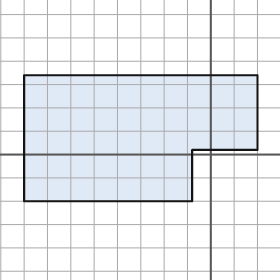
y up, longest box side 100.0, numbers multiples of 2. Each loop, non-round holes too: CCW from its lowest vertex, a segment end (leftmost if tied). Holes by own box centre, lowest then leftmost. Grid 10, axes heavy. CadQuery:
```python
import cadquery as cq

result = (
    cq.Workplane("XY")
    .moveTo(-80.0, -20.0)
    .lineTo(-8.0, -20.0)
    .lineTo(-8.0, 2.0)
    .lineTo(20.0, 2.0)
    .lineTo(20.0, 34.0)
    .lineTo(-80.0, 34.0)
    .close()
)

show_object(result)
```